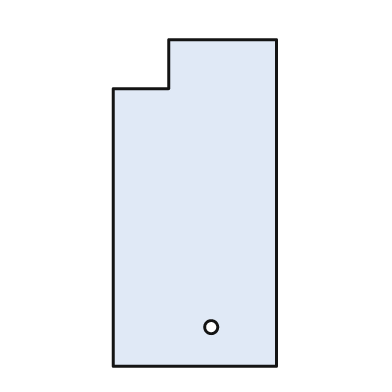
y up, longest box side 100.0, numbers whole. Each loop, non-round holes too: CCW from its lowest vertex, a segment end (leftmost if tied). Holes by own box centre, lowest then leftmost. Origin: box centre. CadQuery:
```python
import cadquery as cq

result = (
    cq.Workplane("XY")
    .moveTo(-25.0, -50.0)
    .lineTo(25.0, -50.0)
    .lineTo(25.0, 50.0)
    .lineTo(-8.0, 50.0)
    .lineTo(-8.0, 35.0)
    .lineTo(-25.0, 35.0)
    .close()
    .moveTo(5.0, -38.0)
    .circle(2.0)
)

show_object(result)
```